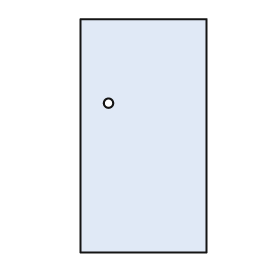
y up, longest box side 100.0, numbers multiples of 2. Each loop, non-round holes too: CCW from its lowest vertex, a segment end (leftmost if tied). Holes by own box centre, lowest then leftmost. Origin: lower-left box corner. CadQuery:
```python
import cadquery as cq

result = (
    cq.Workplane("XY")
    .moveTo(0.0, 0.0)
    .lineTo(54.0, 0.0)
    .lineTo(54.0, 100.0)
    .lineTo(0.0, 100.0)
    .close()
    .moveTo(12.0, 64.0)
    .circle(2.0)
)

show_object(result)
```